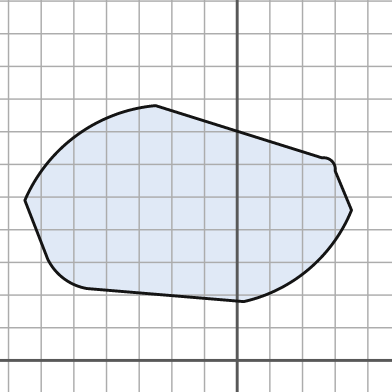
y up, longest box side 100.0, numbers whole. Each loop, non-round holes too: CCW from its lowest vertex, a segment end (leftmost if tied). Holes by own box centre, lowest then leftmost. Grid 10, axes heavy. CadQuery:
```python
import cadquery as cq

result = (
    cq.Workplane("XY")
    .moveTo(2.0, 18.0)
    .threePointArc((22.0, 28.0), (35.0, 46.0))
    .lineTo(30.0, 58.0)
    .threePointArc((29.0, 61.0), (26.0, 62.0))
    .lineTo(-25.0, 78.0)
    .threePointArc((-49.0, 69.0), (-65.0, 49.0))
    .lineTo(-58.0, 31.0)
    .threePointArc((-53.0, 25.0), (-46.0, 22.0))
    .close()
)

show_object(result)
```